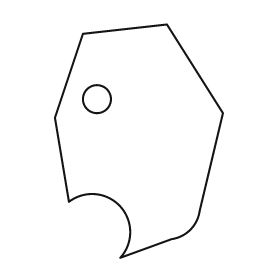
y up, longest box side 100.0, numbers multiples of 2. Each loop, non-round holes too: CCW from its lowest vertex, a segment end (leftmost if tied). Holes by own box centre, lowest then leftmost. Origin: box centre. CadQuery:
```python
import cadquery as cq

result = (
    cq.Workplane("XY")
    .moveTo(-8.0, -50.0)
    .lineTo(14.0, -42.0)
    .threePointArc((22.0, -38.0), (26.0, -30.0))
    .lineTo(36.0, 12.0)
    .lineTo(12.0, 50.0)
    .lineTo(-24.0, 46.0)
    .lineTo(-36.0, 10.0)
    .lineTo(-30.0, -26.0)
    .threePointArc((-8.0, -28.0), (-8.0, -50.0))
    .close()
    .moveTo(-18.0, 18.0)
    .circle(6.0)
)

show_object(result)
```